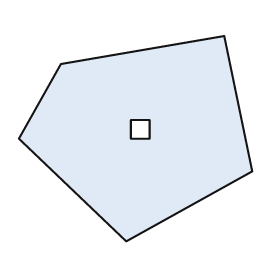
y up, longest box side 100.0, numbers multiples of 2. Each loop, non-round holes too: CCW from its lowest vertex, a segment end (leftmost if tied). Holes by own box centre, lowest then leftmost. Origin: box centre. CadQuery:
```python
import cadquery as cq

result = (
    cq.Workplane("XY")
    .moveTo(-4.0, -44.0)
    .lineTo(50.0, -14.0)
    .lineTo(38.0, 44.0)
    .lineTo(-32.0, 32.0)
    .lineTo(-50.0, 0.0)
    .close()
    .moveTo(-2.0, 0.0)
    .lineTo(6.0, 0.0)
    .lineTo(6.0, 8.0)
    .lineTo(-2.0, 8.0)
    .close()
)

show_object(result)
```